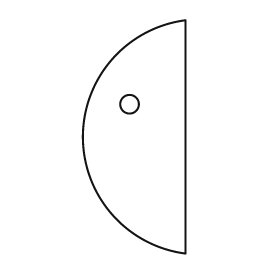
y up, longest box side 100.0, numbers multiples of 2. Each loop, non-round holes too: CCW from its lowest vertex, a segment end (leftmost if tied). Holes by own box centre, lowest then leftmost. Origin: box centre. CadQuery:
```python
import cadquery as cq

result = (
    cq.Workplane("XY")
    .moveTo(22.0, -50.0)
    .lineTo(22.0, 50.0)
    .threePointArc((-22.0, 0.0), (22.0, -50.0))
    .close()
    .moveTo(-2.0, 14.0)
    .circle(4.0)
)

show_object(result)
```